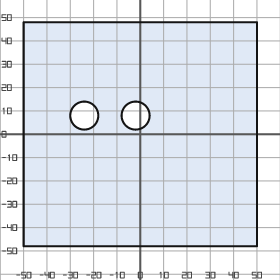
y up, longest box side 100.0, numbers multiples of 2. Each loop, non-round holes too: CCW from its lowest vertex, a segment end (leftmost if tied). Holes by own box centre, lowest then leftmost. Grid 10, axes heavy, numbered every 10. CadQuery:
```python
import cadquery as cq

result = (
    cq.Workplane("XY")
    .moveTo(-50.0, -48.0)
    .lineTo(50.0, -48.0)
    .lineTo(50.0, 48.0)
    .lineTo(-50.0, 48.0)
    .close()
    .moveTo(-24.0, 8.0)
    .circle(6.0)
    .moveTo(-2.0, 8.0)
    .circle(6.0)
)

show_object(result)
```